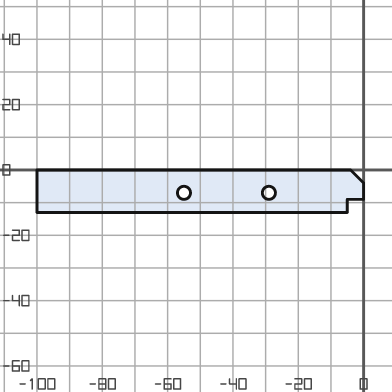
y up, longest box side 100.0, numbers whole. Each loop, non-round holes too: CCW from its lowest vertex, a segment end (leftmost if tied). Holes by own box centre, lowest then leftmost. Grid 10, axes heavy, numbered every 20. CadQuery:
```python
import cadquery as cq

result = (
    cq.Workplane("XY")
    .moveTo(-100.0, -13.0)
    .lineTo(-5.0, -13.0)
    .lineTo(-5.0, -9.0)
    .lineTo(0.0, -9.0)
    .lineTo(0.0, -4.0)
    .lineTo(-4.0, 0.0)
    .lineTo(-100.0, 0.0)
    .close()
    .moveTo(-55.0, -7.0)
    .circle(2.0)
    .moveTo(-29.0, -7.0)
    .circle(2.0)
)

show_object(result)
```